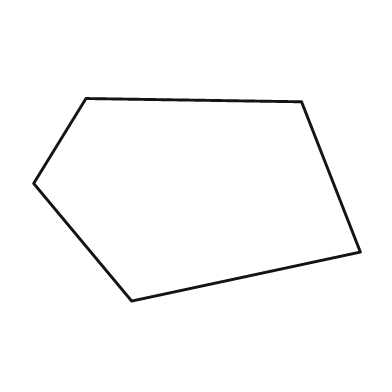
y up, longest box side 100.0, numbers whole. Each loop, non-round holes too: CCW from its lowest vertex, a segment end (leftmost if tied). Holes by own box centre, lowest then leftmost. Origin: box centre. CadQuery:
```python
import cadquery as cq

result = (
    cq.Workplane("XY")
    .moveTo(-20.0, -31.0)
    .lineTo(50.0, -16.0)
    .lineTo(32.0, 30.0)
    .lineTo(-34.0, 31.0)
    .lineTo(-50.0, 5.0)
    .close()
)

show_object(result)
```